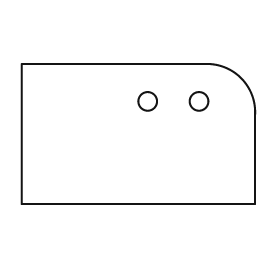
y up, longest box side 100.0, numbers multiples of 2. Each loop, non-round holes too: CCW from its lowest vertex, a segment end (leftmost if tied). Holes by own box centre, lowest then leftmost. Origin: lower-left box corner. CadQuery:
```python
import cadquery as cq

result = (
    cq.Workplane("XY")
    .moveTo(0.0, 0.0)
    .lineTo(100.0, 0.0)
    .lineTo(100.0, 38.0)
    .threePointArc((94.0, 54.0), (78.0, 60.0))
    .lineTo(0.0, 60.0)
    .close()
    .moveTo(54.0, 44.0)
    .circle(4.0)
    .moveTo(76.0, 44.0)
    .circle(4.0)
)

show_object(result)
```